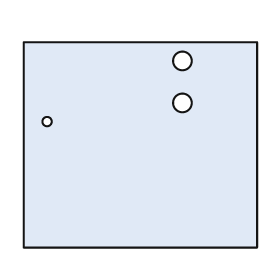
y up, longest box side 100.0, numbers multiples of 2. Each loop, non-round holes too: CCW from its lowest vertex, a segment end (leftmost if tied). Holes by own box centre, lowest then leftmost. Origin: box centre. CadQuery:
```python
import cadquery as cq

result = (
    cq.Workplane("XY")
    .moveTo(-50.0, -44.0)
    .lineTo(50.0, -44.0)
    .lineTo(50.0, 44.0)
    .lineTo(-50.0, 44.0)
    .close()
    .moveTo(-40.0, 10.0)
    .circle(2.0)
    .moveTo(18.0, 18.0)
    .circle(4.0)
    .moveTo(18.0, 36.0)
    .circle(4.0)
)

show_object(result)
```